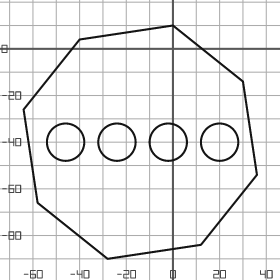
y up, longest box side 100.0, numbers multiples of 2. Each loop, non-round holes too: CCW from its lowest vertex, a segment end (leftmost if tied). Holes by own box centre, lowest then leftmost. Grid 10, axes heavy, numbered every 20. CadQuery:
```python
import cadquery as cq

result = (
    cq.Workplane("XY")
    .moveTo(-28.0, -90.0)
    .lineTo(12.0, -84.0)
    .lineTo(36.0, -54.0)
    .lineTo(30.0, -14.0)
    .lineTo(0.0, 10.0)
    .lineTo(-40.0, 4.0)
    .lineTo(-64.0, -26.0)
    .lineTo(-58.0, -66.0)
    .close()
    .moveTo(-46.0, -40.0)
    .circle(8.0)
    .moveTo(-24.0, -40.0)
    .circle(8.0)
    .moveTo(-2.0, -40.0)
    .circle(8.0)
    .moveTo(20.0, -40.0)
    .circle(8.0)
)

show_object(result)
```